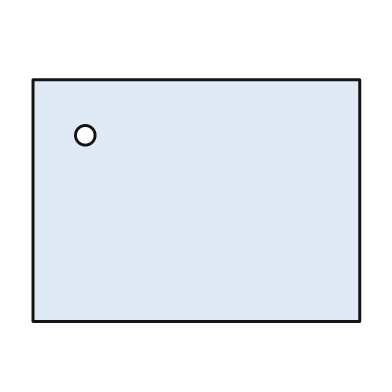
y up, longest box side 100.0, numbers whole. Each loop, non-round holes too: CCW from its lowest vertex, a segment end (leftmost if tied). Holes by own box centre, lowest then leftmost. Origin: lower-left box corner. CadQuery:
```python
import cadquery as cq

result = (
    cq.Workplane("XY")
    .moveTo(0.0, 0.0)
    .lineTo(100.0, 0.0)
    .lineTo(100.0, 74.0)
    .lineTo(0.0, 74.0)
    .close()
    .moveTo(16.0, 57.0)
    .circle(3.0)
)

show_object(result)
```